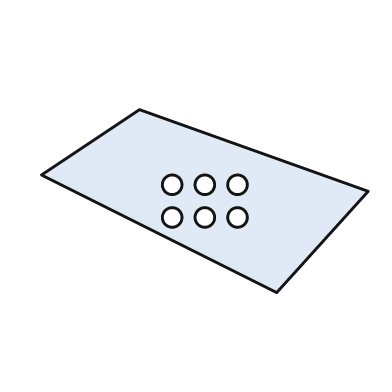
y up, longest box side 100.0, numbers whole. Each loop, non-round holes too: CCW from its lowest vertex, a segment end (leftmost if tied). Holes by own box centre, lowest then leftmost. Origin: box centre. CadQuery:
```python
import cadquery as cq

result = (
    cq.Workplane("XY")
    .moveTo(22.0, -28.0)
    .lineTo(50.0, 3.0)
    .lineTo(-20.0, 28.0)
    .lineTo(-50.0, 8.0)
    .close()
    .moveTo(-10.0, -5.0)
    .circle(3.0)
    .moveTo(0.0, -5.0)
    .circle(3.0)
    .moveTo(10.0, -5.0)
    .circle(3.0)
    .moveTo(-10.0, 5.0)
    .circle(3.0)
    .moveTo(0.0, 5.0)
    .circle(3.0)
    .moveTo(10.0, 5.0)
    .circle(3.0)
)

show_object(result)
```